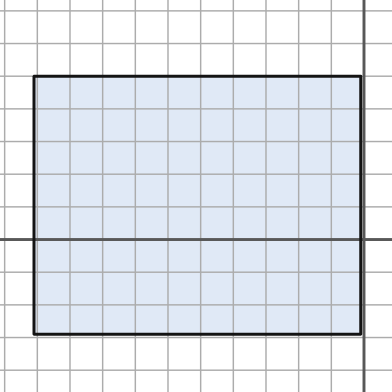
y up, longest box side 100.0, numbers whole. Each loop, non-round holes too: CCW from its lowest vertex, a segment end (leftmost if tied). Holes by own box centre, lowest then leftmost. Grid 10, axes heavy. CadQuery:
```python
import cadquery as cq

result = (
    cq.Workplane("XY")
    .moveTo(-101.0, -29.0)
    .lineTo(-1.0, -29.0)
    .lineTo(-1.0, 50.0)
    .lineTo(-101.0, 50.0)
    .close()
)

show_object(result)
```